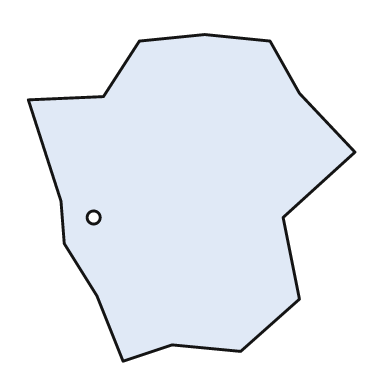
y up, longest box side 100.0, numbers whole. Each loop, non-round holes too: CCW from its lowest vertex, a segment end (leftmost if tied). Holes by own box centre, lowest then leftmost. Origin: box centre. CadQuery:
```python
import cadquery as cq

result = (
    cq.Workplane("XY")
    .moveTo(-21.0, -50.0)
    .lineTo(-6.0, -45.0)
    .lineTo(15.0, -47.0)
    .lineTo(33.0, -31.0)
    .lineTo(28.0, -6.0)
    .lineTo(50.0, 14.0)
    .lineTo(33.0, 32.0)
    .lineTo(24.0, 48.0)
    .lineTo(4.0, 50.0)
    .lineTo(-16.0, 48.0)
    .lineTo(-27.0, 31.0)
    .lineTo(-50.0, 30.0)
    .lineTo(-40.0, -1.0)
    .lineTo(-39.0, -14.0)
    .lineTo(-29.0, -30.0)
    .close()
    .moveTo(-30.0, -6.0)
    .circle(2.0)
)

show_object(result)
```